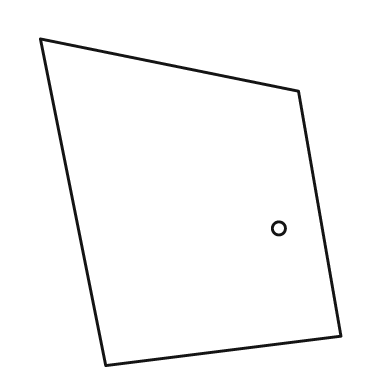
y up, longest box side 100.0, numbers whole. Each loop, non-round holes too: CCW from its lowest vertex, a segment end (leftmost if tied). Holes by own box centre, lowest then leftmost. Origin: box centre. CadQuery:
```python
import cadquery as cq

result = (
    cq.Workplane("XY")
    .moveTo(-26.0, -50.0)
    .lineTo(46.0, -41.0)
    .lineTo(33.0, 34.0)
    .lineTo(-46.0, 50.0)
    .close()
    .moveTo(27.0, -8.0)
    .circle(2.0)
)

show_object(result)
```